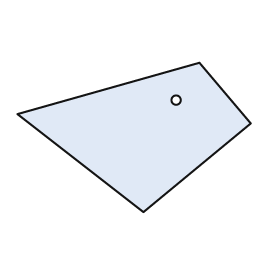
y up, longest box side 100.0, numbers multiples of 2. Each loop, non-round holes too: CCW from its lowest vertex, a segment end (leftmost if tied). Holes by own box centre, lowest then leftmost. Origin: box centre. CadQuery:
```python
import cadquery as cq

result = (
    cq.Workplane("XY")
    .moveTo(4.0, -32.0)
    .lineTo(50.0, 6.0)
    .lineTo(28.0, 32.0)
    .lineTo(-50.0, 10.0)
    .close()
    .moveTo(18.0, 16.0)
    .circle(2.0)
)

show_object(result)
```